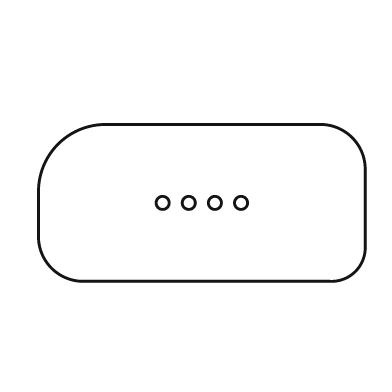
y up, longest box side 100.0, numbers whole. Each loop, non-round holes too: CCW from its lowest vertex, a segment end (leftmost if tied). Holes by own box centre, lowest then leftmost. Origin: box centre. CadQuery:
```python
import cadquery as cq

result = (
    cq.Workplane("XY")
    .moveTo(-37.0, -24.0)
    .lineTo(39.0, -24.0)
    .threePointArc((47.0, -21.0), (50.0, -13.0))
    .lineTo(50.0, 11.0)
    .threePointArc((46.0, 20.0), (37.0, 24.0))
    .lineTo(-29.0, 24.0)
    .threePointArc((-44.0, 18.0), (-50.0, 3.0))
    .lineTo(-50.0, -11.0)
    .threePointArc((-46.0, -20.0), (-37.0, -24.0))
    .close()
    .moveTo(-12.0, 0.0)
    .circle(2.0)
    .moveTo(-4.0, 0.0)
    .circle(2.0)
    .moveTo(4.0, 0.0)
    .circle(2.0)
    .moveTo(12.0, 0.0)
    .circle(2.0)
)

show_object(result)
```